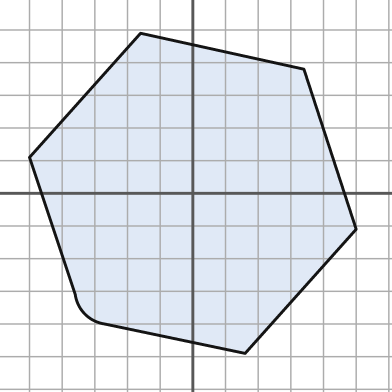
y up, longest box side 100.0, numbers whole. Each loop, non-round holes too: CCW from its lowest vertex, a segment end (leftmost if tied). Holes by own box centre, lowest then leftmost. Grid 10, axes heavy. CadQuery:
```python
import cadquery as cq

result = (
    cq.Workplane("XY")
    .moveTo(16.0, -49.0)
    .lineTo(50.0, -11.0)
    .lineTo(34.0, 38.0)
    .lineTo(-16.0, 49.0)
    .lineTo(-50.0, 11.0)
    .lineTo(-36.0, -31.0)
    .threePointArc((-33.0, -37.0), (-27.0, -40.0))
    .close()
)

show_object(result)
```